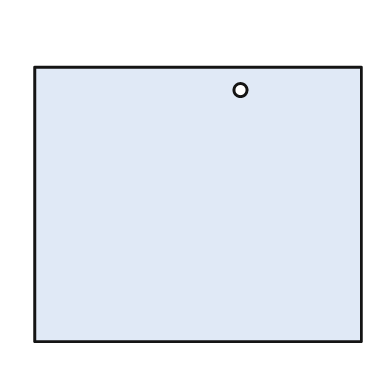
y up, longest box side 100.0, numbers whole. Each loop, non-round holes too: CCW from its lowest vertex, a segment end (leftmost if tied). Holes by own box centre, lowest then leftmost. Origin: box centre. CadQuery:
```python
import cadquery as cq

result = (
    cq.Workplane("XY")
    .moveTo(-50.0, -42.0)
    .lineTo(50.0, -42.0)
    .lineTo(50.0, 42.0)
    .lineTo(-50.0, 42.0)
    .close()
    .moveTo(13.0, 35.0)
    .circle(2.0)
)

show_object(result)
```